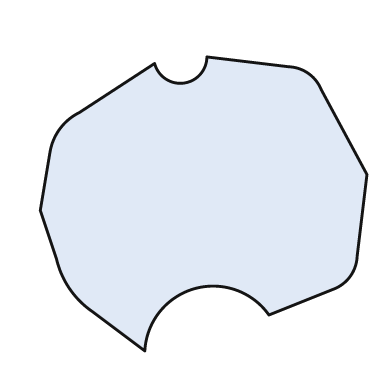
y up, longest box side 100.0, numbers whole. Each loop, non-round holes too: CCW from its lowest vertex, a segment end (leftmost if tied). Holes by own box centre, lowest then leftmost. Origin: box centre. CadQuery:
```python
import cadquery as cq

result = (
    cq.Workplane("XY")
    .moveTo(-18.0, -45.0)
    .threePointArc((-3.0, -26.0), (20.0, -34.0))
    .lineTo(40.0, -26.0)
    .threePointArc((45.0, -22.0), (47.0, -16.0))
    .lineTo(50.0, 9.0)
    .lineTo(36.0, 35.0)
    .threePointArc((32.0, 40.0), (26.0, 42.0))
    .lineTo(1.0, 45.0)
    .threePointArc((-6.0, 37.0), (-15.0, 43.0))
    .lineTo(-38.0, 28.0)
    .threePointArc((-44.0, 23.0), (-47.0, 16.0))
    .lineTo(-50.0, -2.0)
    .lineTo(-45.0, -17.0)
    .threePointArc((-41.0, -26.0), (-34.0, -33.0))
    .close()
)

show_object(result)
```